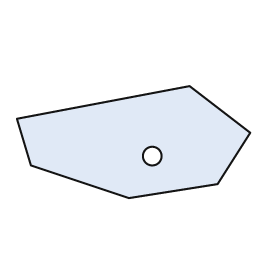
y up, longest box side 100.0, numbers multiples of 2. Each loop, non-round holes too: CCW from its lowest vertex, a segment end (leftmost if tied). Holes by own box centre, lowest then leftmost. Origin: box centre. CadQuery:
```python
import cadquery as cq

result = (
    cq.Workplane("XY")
    .moveTo(-2.0, -24.0)
    .lineTo(36.0, -18.0)
    .lineTo(50.0, 4.0)
    .lineTo(24.0, 24.0)
    .lineTo(-50.0, 10.0)
    .lineTo(-44.0, -10.0)
    .close()
    .moveTo(8.0, -6.0)
    .circle(4.0)
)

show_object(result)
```